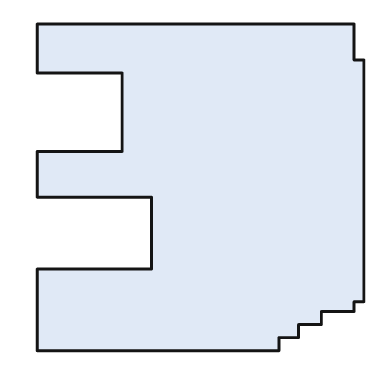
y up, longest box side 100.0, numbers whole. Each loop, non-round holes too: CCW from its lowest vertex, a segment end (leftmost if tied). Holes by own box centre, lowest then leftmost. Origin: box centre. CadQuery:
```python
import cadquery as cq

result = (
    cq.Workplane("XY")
    .moveTo(-50.0, -50.0)
    .lineTo(24.0, -50.0)
    .lineTo(24.0, -46.0)
    .lineTo(30.0, -46.0)
    .lineTo(30.0, -42.0)
    .lineTo(37.0, -42.0)
    .lineTo(37.0, -38.0)
    .lineTo(47.0, -38.0)
    .lineTo(47.0, -35.0)
    .lineTo(50.0, -35.0)
    .lineTo(50.0, 39.0)
    .lineTo(47.0, 39.0)
    .lineTo(47.0, 50.0)
    .lineTo(-50.0, 50.0)
    .lineTo(-50.0, 35.0)
    .lineTo(-24.0, 35.0)
    .lineTo(-24.0, 11.0)
    .lineTo(-50.0, 11.0)
    .lineTo(-50.0, -3.0)
    .lineTo(-15.0, -3.0)
    .lineTo(-15.0, -25.0)
    .lineTo(-50.0, -25.0)
    .close()
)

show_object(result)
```